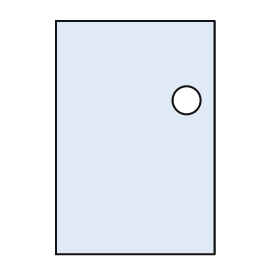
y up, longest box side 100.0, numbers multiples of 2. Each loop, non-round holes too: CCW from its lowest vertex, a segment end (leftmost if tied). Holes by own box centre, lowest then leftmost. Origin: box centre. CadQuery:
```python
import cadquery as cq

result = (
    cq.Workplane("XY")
    .moveTo(-34.0, -50.0)
    .lineTo(34.0, -50.0)
    .lineTo(34.0, 50.0)
    .lineTo(-34.0, 50.0)
    .close()
    .moveTo(22.0, 16.0)
    .circle(6.0)
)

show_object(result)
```